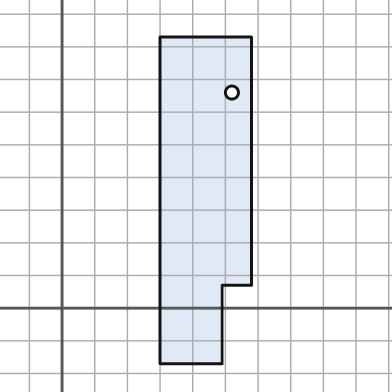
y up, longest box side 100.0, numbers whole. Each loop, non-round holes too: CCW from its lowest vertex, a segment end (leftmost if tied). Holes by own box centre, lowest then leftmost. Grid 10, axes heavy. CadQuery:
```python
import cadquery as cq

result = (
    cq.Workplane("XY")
    .moveTo(30.0, -17.0)
    .lineTo(49.0, -17.0)
    .lineTo(49.0, 7.0)
    .lineTo(58.0, 7.0)
    .lineTo(58.0, 83.0)
    .lineTo(30.0, 83.0)
    .close()
    .moveTo(52.0, 66.0)
    .circle(2.0)
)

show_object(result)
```